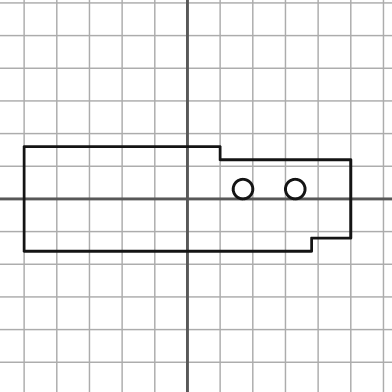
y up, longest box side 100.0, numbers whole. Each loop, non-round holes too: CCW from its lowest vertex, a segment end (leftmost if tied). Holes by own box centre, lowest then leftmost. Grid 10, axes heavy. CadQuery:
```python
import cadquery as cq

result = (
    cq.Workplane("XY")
    .moveTo(-50.0, -16.0)
    .lineTo(38.0, -16.0)
    .lineTo(38.0, -12.0)
    .lineTo(50.0, -12.0)
    .lineTo(50.0, 12.0)
    .lineTo(10.0, 12.0)
    .lineTo(10.0, 16.0)
    .lineTo(-50.0, 16.0)
    .close()
    .moveTo(17.0, 3.0)
    .circle(3.0)
    .moveTo(33.0, 3.0)
    .circle(3.0)
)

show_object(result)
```